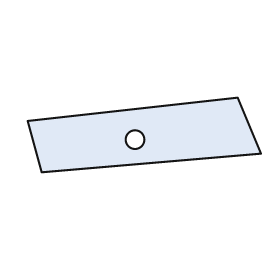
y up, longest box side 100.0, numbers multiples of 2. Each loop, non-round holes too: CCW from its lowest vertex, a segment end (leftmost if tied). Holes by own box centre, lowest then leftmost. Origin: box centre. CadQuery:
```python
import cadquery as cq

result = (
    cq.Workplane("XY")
    .moveTo(-44.0, -16.0)
    .lineTo(50.0, -8.0)
    .lineTo(40.0, 16.0)
    .lineTo(-50.0, 6.0)
    .close()
    .moveTo(-4.0, -2.0)
    .circle(4.0)
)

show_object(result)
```